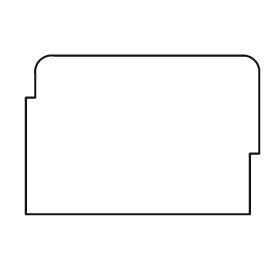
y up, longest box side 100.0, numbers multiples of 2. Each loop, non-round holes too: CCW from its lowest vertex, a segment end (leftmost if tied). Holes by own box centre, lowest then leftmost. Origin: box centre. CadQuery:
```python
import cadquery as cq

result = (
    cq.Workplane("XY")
    .moveTo(-50.0, -34.0)
    .lineTo(46.0, -34.0)
    .lineTo(46.0, -8.0)
    .lineTo(50.0, -8.0)
    .lineTo(50.0, 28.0)
    .threePointArc((48.0, 32.0), (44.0, 34.0))
    .lineTo(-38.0, 34.0)
    .threePointArc((-44.0, 32.0), (-46.0, 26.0))
    .lineTo(-46.0, 16.0)
    .lineTo(-50.0, 16.0)
    .close()
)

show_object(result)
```